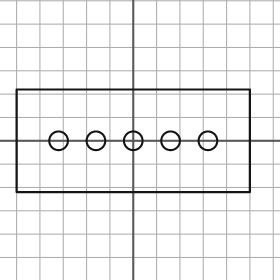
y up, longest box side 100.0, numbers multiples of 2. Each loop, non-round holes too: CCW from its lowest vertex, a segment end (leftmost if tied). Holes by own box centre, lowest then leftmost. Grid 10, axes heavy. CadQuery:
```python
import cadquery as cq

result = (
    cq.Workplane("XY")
    .moveTo(-50.0, -22.0)
    .lineTo(50.0, -22.0)
    .lineTo(50.0, 22.0)
    .lineTo(-50.0, 22.0)
    .close()
    .moveTo(-32.0, 0.0)
    .circle(4.0)
    .moveTo(-16.0, 0.0)
    .circle(4.0)
    .moveTo(0.0, 0.0)
    .circle(4.0)
    .moveTo(16.0, 0.0)
    .circle(4.0)
    .moveTo(32.0, 0.0)
    .circle(4.0)
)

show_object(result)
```